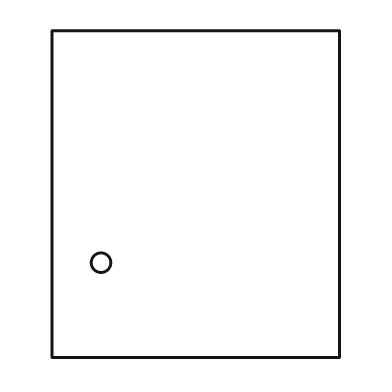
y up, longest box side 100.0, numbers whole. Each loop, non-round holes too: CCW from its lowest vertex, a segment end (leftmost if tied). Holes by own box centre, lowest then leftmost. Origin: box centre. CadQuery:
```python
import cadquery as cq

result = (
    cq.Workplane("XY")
    .moveTo(-44.0, -50.0)
    .lineTo(44.0, -50.0)
    .lineTo(44.0, 50.0)
    .lineTo(-44.0, 50.0)
    .close()
    .moveTo(-29.0, -21.0)
    .circle(3.0)
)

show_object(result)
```